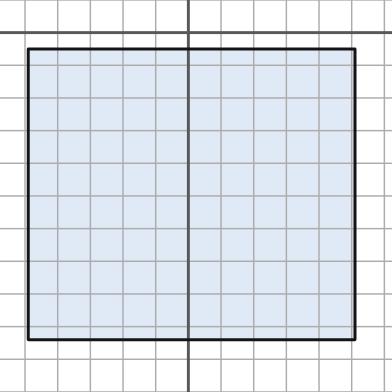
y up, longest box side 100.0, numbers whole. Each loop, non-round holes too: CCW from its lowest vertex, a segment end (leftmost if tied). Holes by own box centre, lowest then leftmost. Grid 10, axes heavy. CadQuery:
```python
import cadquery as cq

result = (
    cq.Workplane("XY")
    .moveTo(-49.0, -94.0)
    .lineTo(51.0, -94.0)
    .lineTo(51.0, -5.0)
    .lineTo(-49.0, -5.0)
    .close()
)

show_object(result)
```